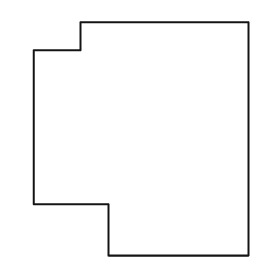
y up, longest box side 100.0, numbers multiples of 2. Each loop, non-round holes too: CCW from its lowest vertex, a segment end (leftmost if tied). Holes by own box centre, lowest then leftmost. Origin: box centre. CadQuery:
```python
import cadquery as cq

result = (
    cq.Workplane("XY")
    .moveTo(-14.0, -50.0)
    .lineTo(46.0, -50.0)
    .lineTo(46.0, 50.0)
    .lineTo(-26.0, 50.0)
    .lineTo(-26.0, 38.0)
    .lineTo(-46.0, 38.0)
    .lineTo(-46.0, -28.0)
    .lineTo(-14.0, -28.0)
    .close()
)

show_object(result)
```